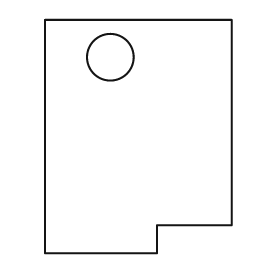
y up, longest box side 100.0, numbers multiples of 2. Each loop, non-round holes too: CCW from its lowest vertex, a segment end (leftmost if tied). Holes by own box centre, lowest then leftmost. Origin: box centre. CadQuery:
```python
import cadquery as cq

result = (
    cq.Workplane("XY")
    .moveTo(-40.0, -50.0)
    .lineTo(8.0, -50.0)
    .lineTo(8.0, -38.0)
    .lineTo(40.0, -38.0)
    .lineTo(40.0, 50.0)
    .lineTo(-40.0, 50.0)
    .close()
    .moveTo(-12.0, 34.0)
    .circle(10.0)
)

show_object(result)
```